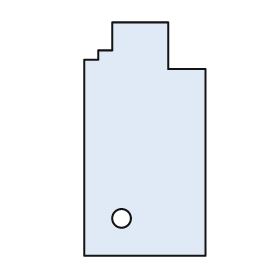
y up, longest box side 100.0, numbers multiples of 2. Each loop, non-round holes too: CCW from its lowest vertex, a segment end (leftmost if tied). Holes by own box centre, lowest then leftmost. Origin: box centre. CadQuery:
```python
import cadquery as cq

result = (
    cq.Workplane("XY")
    .moveTo(-26.0, -50.0)
    .lineTo(26.0, -50.0)
    .lineTo(26.0, 30.0)
    .lineTo(10.0, 30.0)
    .lineTo(10.0, 50.0)
    .lineTo(-14.0, 50.0)
    .lineTo(-14.0, 38.0)
    .lineTo(-20.0, 38.0)
    .lineTo(-20.0, 34.0)
    .lineTo(-26.0, 34.0)
    .close()
    .moveTo(-10.0, -34.0)
    .circle(4.0)
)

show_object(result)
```